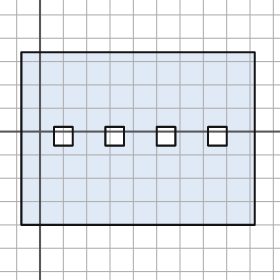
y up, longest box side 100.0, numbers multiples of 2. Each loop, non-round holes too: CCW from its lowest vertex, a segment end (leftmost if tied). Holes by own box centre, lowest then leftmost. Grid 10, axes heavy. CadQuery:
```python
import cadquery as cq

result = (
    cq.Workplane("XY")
    .moveTo(-8.0, -40.0)
    .lineTo(92.0, -40.0)
    .lineTo(92.0, 34.0)
    .lineTo(-8.0, 34.0)
    .close()
    .moveTo(6.0, -6.0)
    .lineTo(14.0, -6.0)
    .lineTo(14.0, 2.0)
    .lineTo(6.0, 2.0)
    .close()
    .moveTo(28.0, -6.0)
    .lineTo(36.0, -6.0)
    .lineTo(36.0, 2.0)
    .lineTo(28.0, 2.0)
    .close()
    .moveTo(50.0, -6.0)
    .lineTo(58.0, -6.0)
    .lineTo(58.0, 2.0)
    .lineTo(50.0, 2.0)
    .close()
    .moveTo(72.0, -6.0)
    .lineTo(80.0, -6.0)
    .lineTo(80.0, 2.0)
    .lineTo(72.0, 2.0)
    .close()
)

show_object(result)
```